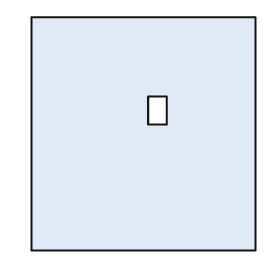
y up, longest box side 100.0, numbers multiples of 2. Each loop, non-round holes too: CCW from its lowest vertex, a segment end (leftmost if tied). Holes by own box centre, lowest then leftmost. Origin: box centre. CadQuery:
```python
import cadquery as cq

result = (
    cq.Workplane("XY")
    .moveTo(-48.0, -50.0)
    .lineTo(48.0, -50.0)
    .lineTo(48.0, 50.0)
    .lineTo(-48.0, 50.0)
    .close()
    .moveTo(2.0, 4.0)
    .lineTo(10.0, 4.0)
    .lineTo(10.0, 16.0)
    .lineTo(2.0, 16.0)
    .close()
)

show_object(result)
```